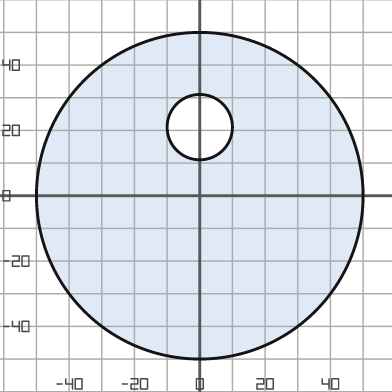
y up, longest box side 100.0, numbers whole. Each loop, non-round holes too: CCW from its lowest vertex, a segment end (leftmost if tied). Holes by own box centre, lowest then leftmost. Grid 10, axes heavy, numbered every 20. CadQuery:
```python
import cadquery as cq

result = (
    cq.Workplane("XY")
    .moveTo(0.0, 0.0)
    .circle(50.0)
    .moveTo(0.0, 21.0)
    .circle(10.0)
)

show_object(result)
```